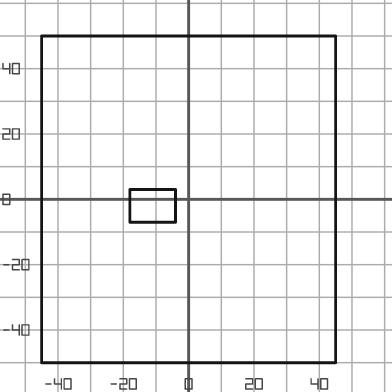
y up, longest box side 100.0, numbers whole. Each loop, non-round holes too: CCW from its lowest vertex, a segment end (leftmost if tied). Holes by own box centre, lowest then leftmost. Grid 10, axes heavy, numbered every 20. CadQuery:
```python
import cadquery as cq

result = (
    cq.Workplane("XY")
    .moveTo(-45.0, -50.0)
    .lineTo(45.0, -50.0)
    .lineTo(45.0, 50.0)
    .lineTo(-45.0, 50.0)
    .close()
    .moveTo(-18.0, -7.0)
    .lineTo(-4.0, -7.0)
    .lineTo(-4.0, 3.0)
    .lineTo(-18.0, 3.0)
    .close()
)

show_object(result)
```